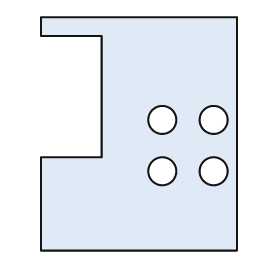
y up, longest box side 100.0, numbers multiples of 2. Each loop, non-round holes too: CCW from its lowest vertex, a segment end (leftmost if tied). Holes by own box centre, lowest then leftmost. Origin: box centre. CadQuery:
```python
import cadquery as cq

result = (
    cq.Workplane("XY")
    .moveTo(-42.0, -50.0)
    .lineTo(42.0, -50.0)
    .lineTo(42.0, 50.0)
    .lineTo(-42.0, 50.0)
    .lineTo(-42.0, 42.0)
    .lineTo(-16.0, 42.0)
    .lineTo(-16.0, -10.0)
    .lineTo(-42.0, -10.0)
    .close()
    .moveTo(10.0, -16.0)
    .circle(6.0)
    .moveTo(32.0, -16.0)
    .circle(6.0)
    .moveTo(10.0, 6.0)
    .circle(6.0)
    .moveTo(32.0, 6.0)
    .circle(6.0)
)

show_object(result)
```